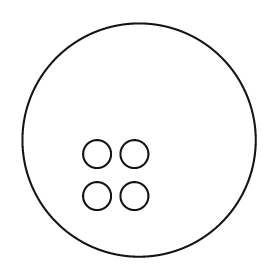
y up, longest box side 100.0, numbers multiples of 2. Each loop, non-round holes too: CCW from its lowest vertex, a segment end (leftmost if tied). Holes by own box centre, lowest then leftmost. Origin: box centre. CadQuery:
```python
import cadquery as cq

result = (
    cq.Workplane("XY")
    .moveTo(0.0, 0.0)
    .circle(50.0)
    .moveTo(-18.0, -24.0)
    .circle(6.0)
    .moveTo(-2.0, -24.0)
    .circle(6.0)
    .moveTo(-18.0, -6.0)
    .circle(6.0)
    .moveTo(-2.0, -6.0)
    .circle(6.0)
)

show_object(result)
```